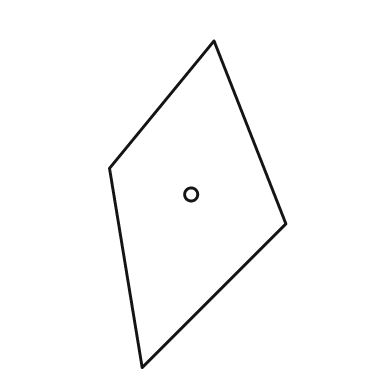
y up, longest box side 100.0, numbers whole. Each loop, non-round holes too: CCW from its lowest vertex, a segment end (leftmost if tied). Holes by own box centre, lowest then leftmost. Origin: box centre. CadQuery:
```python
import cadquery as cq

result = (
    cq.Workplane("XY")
    .moveTo(-17.0, -50.0)
    .lineTo(27.0, -6.0)
    .lineTo(5.0, 50.0)
    .lineTo(-27.0, 11.0)
    .close()
    .moveTo(-2.0, 3.0)
    .circle(2.0)
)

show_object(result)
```